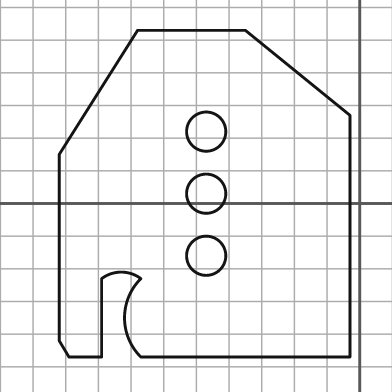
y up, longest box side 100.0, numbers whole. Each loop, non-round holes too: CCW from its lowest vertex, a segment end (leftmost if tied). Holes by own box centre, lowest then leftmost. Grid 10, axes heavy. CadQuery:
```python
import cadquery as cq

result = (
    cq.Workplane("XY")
    .moveTo(-89.0, -47.0)
    .lineTo(-79.0, -47.0)
    .lineTo(-79.0, -23.0)
    .threePointArc((-73.0, -21.0), (-67.0, -23.0))
    .threePointArc((-72.0, -35.0), (-67.0, -47.0))
    .lineTo(-3.0, -47.0)
    .lineTo(-3.0, 27.0)
    .lineTo(-35.0, 53.0)
    .lineTo(-68.0, 53.0)
    .lineTo(-92.0, 15.0)
    .lineTo(-92.0, -42.0)
    .close()
    .moveTo(-47.0, -16.0)
    .circle(6.0)
    .moveTo(-47.0, 3.0)
    .circle(6.0)
    .moveTo(-47.0, 22.0)
    .circle(6.0)
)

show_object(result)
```